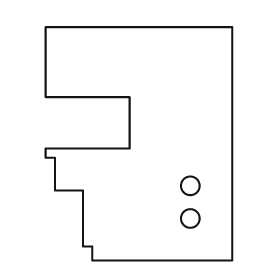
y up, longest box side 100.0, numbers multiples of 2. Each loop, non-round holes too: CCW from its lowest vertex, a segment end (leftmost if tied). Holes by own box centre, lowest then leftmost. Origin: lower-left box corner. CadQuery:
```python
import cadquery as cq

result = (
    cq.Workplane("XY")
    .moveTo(20.0, 0.0)
    .lineTo(80.0, 0.0)
    .lineTo(80.0, 100.0)
    .lineTo(0.0, 100.0)
    .lineTo(0.0, 70.0)
    .lineTo(36.0, 70.0)
    .lineTo(36.0, 48.0)
    .lineTo(0.0, 48.0)
    .lineTo(0.0, 44.0)
    .lineTo(4.0, 44.0)
    .lineTo(4.0, 30.0)
    .lineTo(16.0, 30.0)
    .lineTo(16.0, 6.0)
    .lineTo(20.0, 6.0)
    .close()
    .moveTo(62.0, 18.0)
    .circle(4.0)
    .moveTo(62.0, 32.0)
    .circle(4.0)
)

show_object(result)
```